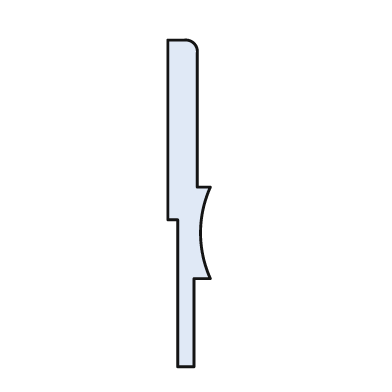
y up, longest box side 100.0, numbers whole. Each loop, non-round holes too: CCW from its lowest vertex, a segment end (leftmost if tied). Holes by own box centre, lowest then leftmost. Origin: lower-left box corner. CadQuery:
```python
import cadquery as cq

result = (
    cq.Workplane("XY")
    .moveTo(3.0, 0.0)
    .lineTo(8.0, 0.0)
    .lineTo(8.0, 27.0)
    .lineTo(13.0, 27.0)
    .threePointArc((10.0, 41.0), (13.0, 55.0))
    .lineTo(9.0, 55.0)
    .lineTo(9.0, 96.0)
    .threePointArc((8.0, 99.0), (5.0, 100.0))
    .lineTo(0.0, 100.0)
    .lineTo(0.0, 45.0)
    .lineTo(3.0, 45.0)
    .close()
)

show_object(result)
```